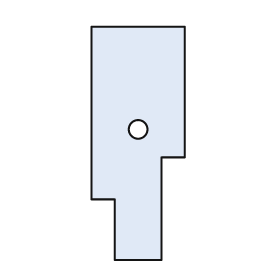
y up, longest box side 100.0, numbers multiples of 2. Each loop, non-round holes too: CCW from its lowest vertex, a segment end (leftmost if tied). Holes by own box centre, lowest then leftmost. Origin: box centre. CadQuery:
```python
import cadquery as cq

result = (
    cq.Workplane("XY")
    .moveTo(-10.0, -50.0)
    .lineTo(10.0, -50.0)
    .lineTo(10.0, -6.0)
    .lineTo(20.0, -6.0)
    .lineTo(20.0, 50.0)
    .lineTo(-20.0, 50.0)
    .lineTo(-20.0, -24.0)
    .lineTo(-10.0, -24.0)
    .close()
    .moveTo(0.0, 6.0)
    .circle(4.0)
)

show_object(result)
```